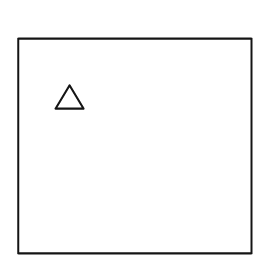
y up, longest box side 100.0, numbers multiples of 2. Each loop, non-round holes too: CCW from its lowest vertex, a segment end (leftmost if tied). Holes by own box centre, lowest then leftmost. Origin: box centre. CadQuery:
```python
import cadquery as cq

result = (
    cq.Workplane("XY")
    .moveTo(-50.0, -46.0)
    .lineTo(50.0, -46.0)
    .lineTo(50.0, 46.0)
    .lineTo(-50.0, 46.0)
    .close()
    .moveTo(-34.0, 16.0)
    .lineTo(-22.0, 16.0)
    .lineTo(-28.0, 26.0)
    .close()
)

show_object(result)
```